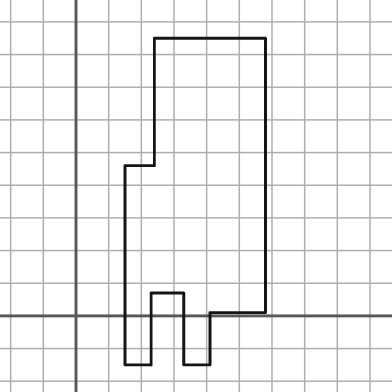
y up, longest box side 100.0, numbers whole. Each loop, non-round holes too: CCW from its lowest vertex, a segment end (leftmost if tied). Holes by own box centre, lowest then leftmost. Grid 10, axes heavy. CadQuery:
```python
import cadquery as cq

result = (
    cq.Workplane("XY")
    .moveTo(15.0, -15.0)
    .lineTo(23.0, -15.0)
    .lineTo(23.0, 7.0)
    .lineTo(33.0, 7.0)
    .lineTo(33.0, -15.0)
    .lineTo(41.0, -15.0)
    .lineTo(41.0, 1.0)
    .lineTo(58.0, 1.0)
    .lineTo(58.0, 85.0)
    .lineTo(24.0, 85.0)
    .lineTo(24.0, 46.0)
    .lineTo(15.0, 46.0)
    .close()
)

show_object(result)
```